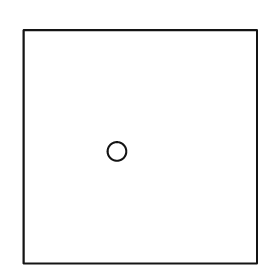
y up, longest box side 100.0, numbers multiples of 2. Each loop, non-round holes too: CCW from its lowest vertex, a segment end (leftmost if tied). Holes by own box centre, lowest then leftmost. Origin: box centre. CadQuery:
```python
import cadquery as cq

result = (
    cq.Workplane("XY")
    .moveTo(-50.0, -50.0)
    .lineTo(50.0, -50.0)
    .lineTo(50.0, 50.0)
    .lineTo(-50.0, 50.0)
    .close()
    .moveTo(-10.0, -2.0)
    .circle(4.0)
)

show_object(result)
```